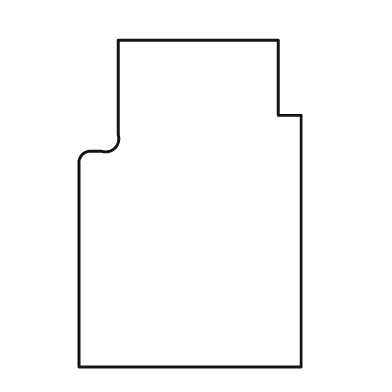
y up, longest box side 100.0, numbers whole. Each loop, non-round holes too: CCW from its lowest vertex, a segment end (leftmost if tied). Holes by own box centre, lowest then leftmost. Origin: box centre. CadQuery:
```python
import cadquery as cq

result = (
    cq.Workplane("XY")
    .moveTo(-34.0, -50.0)
    .lineTo(34.0, -50.0)
    .lineTo(34.0, 27.0)
    .lineTo(27.0, 27.0)
    .lineTo(27.0, 50.0)
    .lineTo(-22.0, 50.0)
    .lineTo(-22.0, 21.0)
    .threePointArc((-23.0, 17.0), (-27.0, 16.0))
    .lineTo(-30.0, 16.0)
    .threePointArc((-33.0, 15.0), (-34.0, 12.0))
    .close()
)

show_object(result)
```